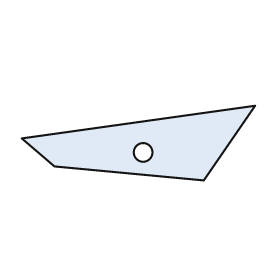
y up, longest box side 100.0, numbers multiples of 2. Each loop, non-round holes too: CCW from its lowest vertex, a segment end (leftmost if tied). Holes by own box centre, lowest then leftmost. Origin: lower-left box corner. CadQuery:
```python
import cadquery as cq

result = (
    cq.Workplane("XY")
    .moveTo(78.0, 0.0)
    .lineTo(100.0, 32.0)
    .lineTo(0.0, 18.0)
    .lineTo(14.0, 6.0)
    .close()
    .moveTo(52.0, 12.0)
    .circle(4.0)
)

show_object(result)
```